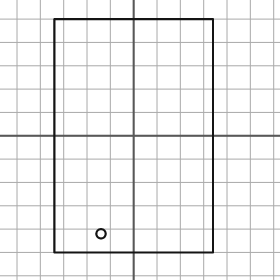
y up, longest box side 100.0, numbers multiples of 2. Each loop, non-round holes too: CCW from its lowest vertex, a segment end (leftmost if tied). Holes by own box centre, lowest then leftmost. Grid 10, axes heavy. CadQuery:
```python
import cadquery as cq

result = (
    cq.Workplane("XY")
    .moveTo(-34.0, -50.0)
    .lineTo(34.0, -50.0)
    .lineTo(34.0, 50.0)
    .lineTo(-34.0, 50.0)
    .close()
    .moveTo(-14.0, -42.0)
    .circle(2.0)
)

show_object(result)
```